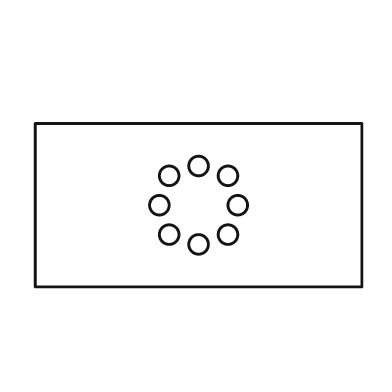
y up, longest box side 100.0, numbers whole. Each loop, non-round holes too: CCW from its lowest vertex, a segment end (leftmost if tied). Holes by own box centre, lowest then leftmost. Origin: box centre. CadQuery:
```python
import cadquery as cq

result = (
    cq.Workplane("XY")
    .moveTo(-50.0, -25.0)
    .lineTo(50.0, -25.0)
    .lineTo(50.0, 25.0)
    .lineTo(-50.0, 25.0)
    .close()
    .moveTo(0.0, -12.0)
    .circle(3.0)
    .moveTo(-9.0, -9.0)
    .circle(3.0)
    .moveTo(9.0, -9.0)
    .circle(3.0)
    .moveTo(-12.0, 0.0)
    .circle(3.0)
    .moveTo(12.0, 0.0)
    .circle(3.0)
    .moveTo(-9.0, 9.0)
    .circle(3.0)
    .moveTo(9.0, 9.0)
    .circle(3.0)
    .moveTo(0.0, 12.0)
    .circle(3.0)
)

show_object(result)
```